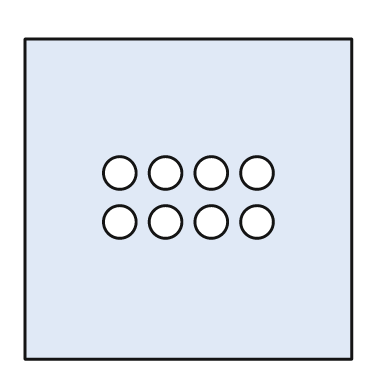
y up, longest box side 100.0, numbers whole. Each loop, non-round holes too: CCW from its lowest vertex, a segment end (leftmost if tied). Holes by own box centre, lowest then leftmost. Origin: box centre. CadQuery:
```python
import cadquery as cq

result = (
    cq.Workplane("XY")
    .moveTo(-50.0, -49.0)
    .lineTo(50.0, -49.0)
    .lineTo(50.0, 49.0)
    .lineTo(-50.0, 49.0)
    .close()
    .moveTo(-21.0, -7.0)
    .circle(5.0)
    .moveTo(-7.0, -7.0)
    .circle(5.0)
    .moveTo(7.0, -7.0)
    .circle(5.0)
    .moveTo(21.0, -7.0)
    .circle(5.0)
    .moveTo(-21.0, 8.0)
    .circle(5.0)
    .moveTo(-7.0, 8.0)
    .circle(5.0)
    .moveTo(7.0, 8.0)
    .circle(5.0)
    .moveTo(21.0, 8.0)
    .circle(5.0)
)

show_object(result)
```